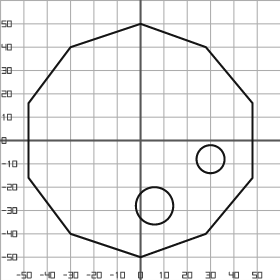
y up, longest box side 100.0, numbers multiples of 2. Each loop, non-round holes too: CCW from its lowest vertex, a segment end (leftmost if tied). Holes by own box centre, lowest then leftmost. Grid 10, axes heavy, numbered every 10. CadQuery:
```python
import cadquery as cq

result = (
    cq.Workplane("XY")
    .moveTo(0.0, -50.0)
    .lineTo(28.0, -40.0)
    .lineTo(48.0, -16.0)
    .lineTo(48.0, 16.0)
    .lineTo(28.0, 40.0)
    .lineTo(0.0, 50.0)
    .lineTo(-30.0, 40.0)
    .lineTo(-48.0, 16.0)
    .lineTo(-48.0, -16.0)
    .lineTo(-30.0, -40.0)
    .close()
    .moveTo(6.0, -28.0)
    .circle(8.0)
    .moveTo(30.0, -8.0)
    .circle(6.0)
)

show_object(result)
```